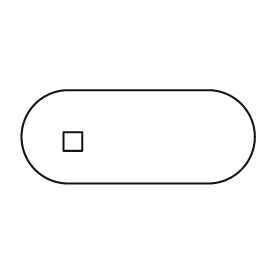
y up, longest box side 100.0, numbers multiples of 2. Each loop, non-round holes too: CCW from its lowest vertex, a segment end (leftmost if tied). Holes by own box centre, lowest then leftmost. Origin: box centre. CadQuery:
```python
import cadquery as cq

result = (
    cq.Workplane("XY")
    .moveTo(-30.0, -20.0)
    .lineTo(30.0, -20.0)
    .threePointArc((50.0, 0.0), (30.0, 20.0))
    .lineTo(-30.0, 20.0)
    .threePointArc((-50.0, 0.0), (-30.0, -20.0))
    .close()
    .moveTo(-32.0, -6.0)
    .lineTo(-24.0, -6.0)
    .lineTo(-24.0, 2.0)
    .lineTo(-32.0, 2.0)
    .close()
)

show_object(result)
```